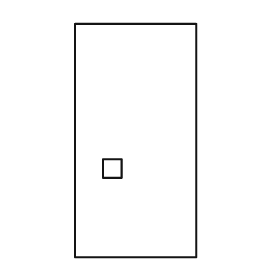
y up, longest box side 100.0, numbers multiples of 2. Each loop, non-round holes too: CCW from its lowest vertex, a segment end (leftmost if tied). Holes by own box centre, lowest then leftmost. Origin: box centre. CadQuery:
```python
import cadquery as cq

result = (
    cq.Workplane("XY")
    .moveTo(-26.0, -50.0)
    .lineTo(26.0, -50.0)
    .lineTo(26.0, 50.0)
    .lineTo(-26.0, 50.0)
    .close()
    .moveTo(-14.0, -16.0)
    .lineTo(-6.0, -16.0)
    .lineTo(-6.0, -8.0)
    .lineTo(-14.0, -8.0)
    .close()
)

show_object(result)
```